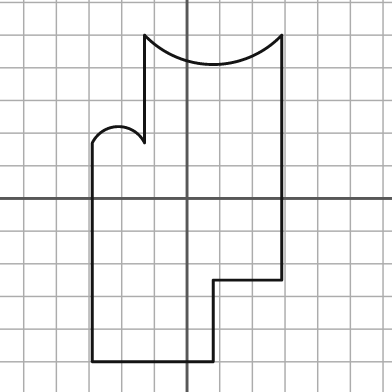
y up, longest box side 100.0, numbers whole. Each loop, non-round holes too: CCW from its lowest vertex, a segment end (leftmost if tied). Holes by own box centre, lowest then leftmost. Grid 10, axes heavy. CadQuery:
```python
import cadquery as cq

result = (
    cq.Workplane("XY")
    .moveTo(-29.0, -50.0)
    .lineTo(8.0, -50.0)
    .lineTo(8.0, -25.0)
    .lineTo(29.0, -25.0)
    .lineTo(29.0, 50.0)
    .threePointArc((8.0, 41.0), (-13.0, 50.0))
    .lineTo(-13.0, 17.0)
    .threePointArc((-21.0, 22.0), (-29.0, 17.0))
    .close()
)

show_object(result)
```